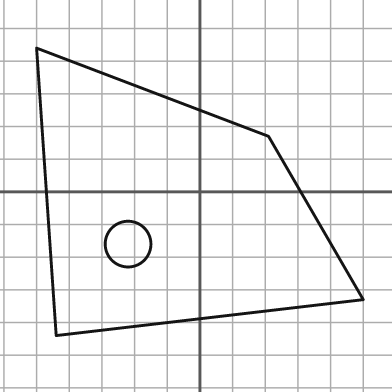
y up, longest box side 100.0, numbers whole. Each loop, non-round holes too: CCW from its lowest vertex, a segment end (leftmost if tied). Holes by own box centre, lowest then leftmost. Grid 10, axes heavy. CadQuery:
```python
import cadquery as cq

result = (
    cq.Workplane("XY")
    .moveTo(-44.0, -44.0)
    .lineTo(50.0, -33.0)
    .lineTo(21.0, 17.0)
    .lineTo(-50.0, 44.0)
    .close()
    .moveTo(-22.0, -16.0)
    .circle(7.0)
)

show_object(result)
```